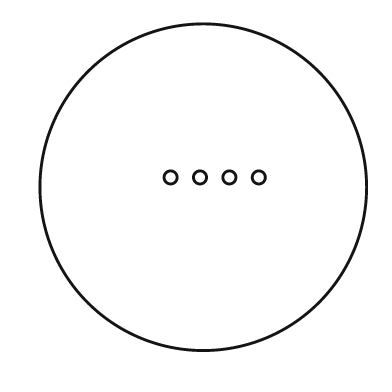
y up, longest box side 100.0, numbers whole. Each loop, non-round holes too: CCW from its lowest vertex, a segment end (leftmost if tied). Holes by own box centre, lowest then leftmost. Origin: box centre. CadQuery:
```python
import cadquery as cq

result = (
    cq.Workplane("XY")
    .moveTo(0.0, 0.0)
    .circle(50.0)
    .moveTo(-10.0, 3.0)
    .circle(2.0)
    .moveTo(-1.0, 3.0)
    .circle(2.0)
    .moveTo(8.0, 3.0)
    .circle(2.0)
    .moveTo(17.0, 3.0)
    .circle(2.0)
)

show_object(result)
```